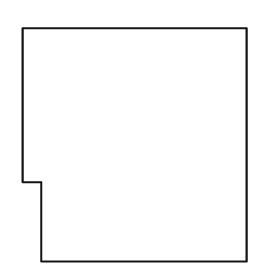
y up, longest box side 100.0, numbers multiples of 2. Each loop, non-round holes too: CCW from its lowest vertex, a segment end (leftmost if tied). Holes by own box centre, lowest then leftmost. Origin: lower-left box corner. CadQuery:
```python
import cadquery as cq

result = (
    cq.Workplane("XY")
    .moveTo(8.0, 0.0)
    .lineTo(96.0, 0.0)
    .lineTo(96.0, 100.0)
    .lineTo(0.0, 100.0)
    .lineTo(0.0, 34.0)
    .lineTo(8.0, 34.0)
    .close()
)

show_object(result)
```